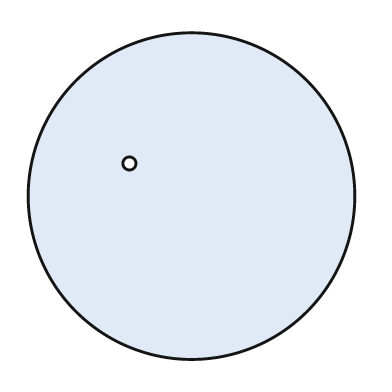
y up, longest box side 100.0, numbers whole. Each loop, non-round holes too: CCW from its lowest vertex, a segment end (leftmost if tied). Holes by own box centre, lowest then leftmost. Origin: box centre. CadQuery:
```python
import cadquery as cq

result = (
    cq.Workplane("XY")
    .moveTo(0.0, 0.0)
    .circle(50.0)
    .moveTo(-19.0, 10.0)
    .circle(2.0)
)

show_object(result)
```